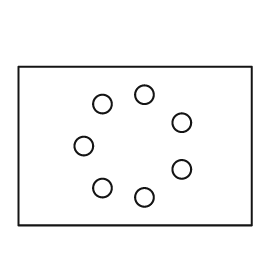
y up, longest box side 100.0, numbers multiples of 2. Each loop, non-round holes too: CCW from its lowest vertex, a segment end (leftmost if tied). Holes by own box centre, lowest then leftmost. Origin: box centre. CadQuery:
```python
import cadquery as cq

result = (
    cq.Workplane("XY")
    .moveTo(-50.0, -34.0)
    .lineTo(50.0, -34.0)
    .lineTo(50.0, 34.0)
    .lineTo(-50.0, 34.0)
    .close()
    .moveTo(4.0, -22.0)
    .circle(4.0)
    .moveTo(-14.0, -18.0)
    .circle(4.0)
    .moveTo(20.0, -10.0)
    .circle(4.0)
    .moveTo(-22.0, 0.0)
    .circle(4.0)
    .moveTo(20.0, 10.0)
    .circle(4.0)
    .moveTo(-14.0, 18.0)
    .circle(4.0)
    .moveTo(4.0, 22.0)
    .circle(4.0)
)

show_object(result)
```